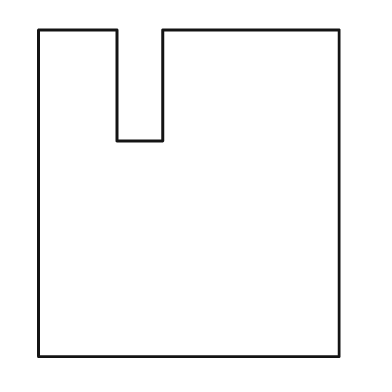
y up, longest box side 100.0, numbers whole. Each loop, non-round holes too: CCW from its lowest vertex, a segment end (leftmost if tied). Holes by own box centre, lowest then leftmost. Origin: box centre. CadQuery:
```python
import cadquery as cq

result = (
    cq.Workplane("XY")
    .moveTo(-46.0, -50.0)
    .lineTo(46.0, -50.0)
    .lineTo(46.0, 50.0)
    .lineTo(-8.0, 50.0)
    .lineTo(-8.0, 16.0)
    .lineTo(-22.0, 16.0)
    .lineTo(-22.0, 50.0)
    .lineTo(-46.0, 50.0)
    .close()
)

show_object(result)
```